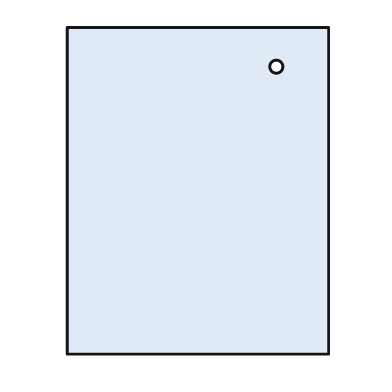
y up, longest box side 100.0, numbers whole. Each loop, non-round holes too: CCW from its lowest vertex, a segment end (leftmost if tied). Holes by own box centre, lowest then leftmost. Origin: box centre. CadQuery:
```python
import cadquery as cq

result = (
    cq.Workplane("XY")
    .moveTo(-40.0, -50.0)
    .lineTo(40.0, -50.0)
    .lineTo(40.0, 50.0)
    .lineTo(-40.0, 50.0)
    .close()
    .moveTo(24.0, 38.0)
    .circle(2.0)
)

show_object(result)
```